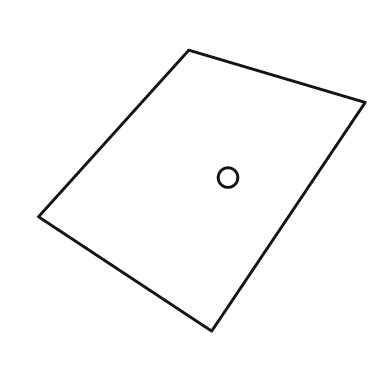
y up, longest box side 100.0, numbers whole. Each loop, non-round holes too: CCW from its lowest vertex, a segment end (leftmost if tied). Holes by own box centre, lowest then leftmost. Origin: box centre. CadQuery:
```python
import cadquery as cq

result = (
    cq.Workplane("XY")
    .moveTo(3.0, -43.0)
    .lineTo(50.0, 27.0)
    .lineTo(-4.0, 43.0)
    .lineTo(-50.0, -8.0)
    .close()
    .moveTo(8.0, 4.0)
    .circle(3.0)
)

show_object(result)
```